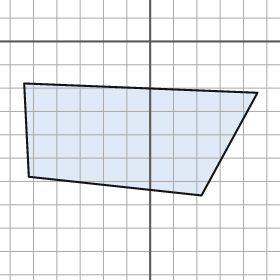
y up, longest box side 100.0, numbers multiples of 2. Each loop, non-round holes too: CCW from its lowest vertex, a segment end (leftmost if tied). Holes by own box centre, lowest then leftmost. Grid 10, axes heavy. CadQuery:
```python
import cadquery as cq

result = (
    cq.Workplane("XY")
    .moveTo(22.0, -66.0)
    .lineTo(46.0, -22.0)
    .lineTo(-54.0, -18.0)
    .lineTo(-52.0, -58.0)
    .close()
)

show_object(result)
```